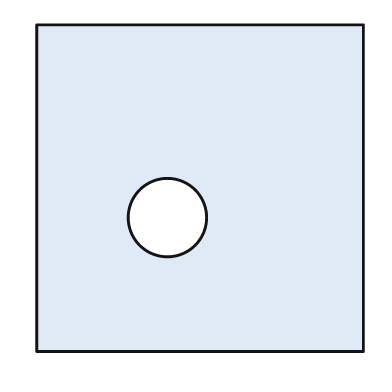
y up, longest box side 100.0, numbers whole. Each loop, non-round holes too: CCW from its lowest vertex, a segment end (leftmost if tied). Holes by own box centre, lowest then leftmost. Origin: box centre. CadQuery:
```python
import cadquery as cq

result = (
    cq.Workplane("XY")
    .moveTo(-50.0, -50.0)
    .lineTo(50.0, -50.0)
    .lineTo(50.0, 50.0)
    .lineTo(-50.0, 50.0)
    .close()
    .moveTo(-10.0, -9.0)
    .circle(12.0)
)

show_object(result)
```